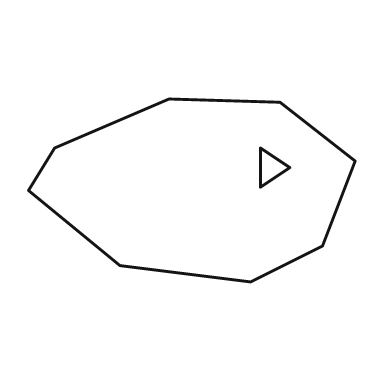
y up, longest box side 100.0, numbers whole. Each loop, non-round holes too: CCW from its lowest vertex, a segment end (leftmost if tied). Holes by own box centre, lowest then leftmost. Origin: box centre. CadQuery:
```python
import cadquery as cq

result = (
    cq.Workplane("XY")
    .moveTo(18.0, -28.0)
    .lineTo(40.0, -17.0)
    .lineTo(50.0, 9.0)
    .lineTo(27.0, 27.0)
    .lineTo(-7.0, 28.0)
    .lineTo(-42.0, 13.0)
    .lineTo(-50.0, 0.0)
    .lineTo(-22.0, -23.0)
    .close()
    .moveTo(21.0, 1.0)
    .lineTo(30.0, 7.0)
    .lineTo(21.0, 13.0)
    .close()
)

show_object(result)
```